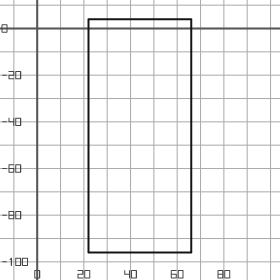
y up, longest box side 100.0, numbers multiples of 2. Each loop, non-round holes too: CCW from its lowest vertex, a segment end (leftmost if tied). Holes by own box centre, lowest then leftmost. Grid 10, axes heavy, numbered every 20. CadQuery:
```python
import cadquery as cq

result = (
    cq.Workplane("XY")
    .moveTo(22.0, -96.0)
    .lineTo(66.0, -96.0)
    .lineTo(66.0, 4.0)
    .lineTo(22.0, 4.0)
    .close()
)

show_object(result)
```